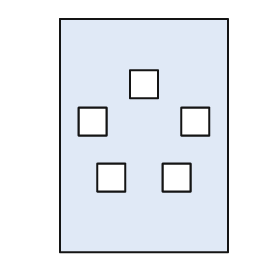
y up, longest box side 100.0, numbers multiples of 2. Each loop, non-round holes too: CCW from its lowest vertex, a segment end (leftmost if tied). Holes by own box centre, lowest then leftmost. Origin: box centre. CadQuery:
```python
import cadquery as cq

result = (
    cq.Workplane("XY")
    .moveTo(-36.0, -50.0)
    .lineTo(36.0, -50.0)
    .lineTo(36.0, 50.0)
    .lineTo(-36.0, 50.0)
    .close()
    .moveTo(-20.0, -24.0)
    .lineTo(-8.0, -24.0)
    .lineTo(-8.0, -12.0)
    .lineTo(-20.0, -12.0)
    .close()
    .moveTo(8.0, -24.0)
    .lineTo(20.0, -24.0)
    .lineTo(20.0, -12.0)
    .lineTo(8.0, -12.0)
    .close()
    .moveTo(-28.0, 0.0)
    .lineTo(-16.0, 0.0)
    .lineTo(-16.0, 12.0)
    .lineTo(-28.0, 12.0)
    .close()
    .moveTo(16.0, 0.0)
    .lineTo(28.0, 0.0)
    .lineTo(28.0, 12.0)
    .lineTo(16.0, 12.0)
    .close()
    .moveTo(-6.0, 16.0)
    .lineTo(6.0, 16.0)
    .lineTo(6.0, 28.0)
    .lineTo(-6.0, 28.0)
    .close()
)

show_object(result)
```